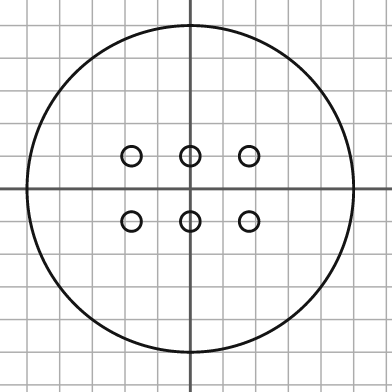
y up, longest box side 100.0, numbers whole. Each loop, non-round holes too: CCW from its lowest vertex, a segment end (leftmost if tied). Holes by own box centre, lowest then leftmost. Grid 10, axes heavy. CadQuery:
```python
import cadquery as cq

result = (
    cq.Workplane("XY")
    .moveTo(0.0, 0.0)
    .circle(50.0)
    .moveTo(-18.0, -10.0)
    .circle(3.0)
    .moveTo(0.0, -10.0)
    .circle(3.0)
    .moveTo(18.0, -10.0)
    .circle(3.0)
    .moveTo(-18.0, 10.0)
    .circle(3.0)
    .moveTo(0.0, 10.0)
    .circle(3.0)
    .moveTo(18.0, 10.0)
    .circle(3.0)
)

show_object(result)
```